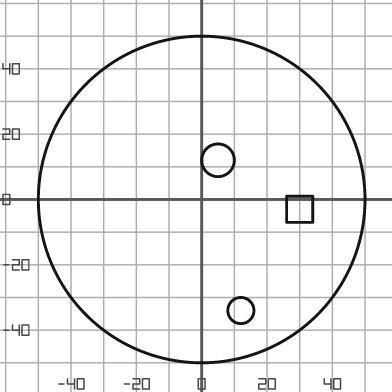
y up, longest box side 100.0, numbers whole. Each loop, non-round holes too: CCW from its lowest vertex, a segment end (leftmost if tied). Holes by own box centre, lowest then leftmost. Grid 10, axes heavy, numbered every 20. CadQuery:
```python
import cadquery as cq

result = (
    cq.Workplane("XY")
    .moveTo(0.0, 0.0)
    .circle(50.0)
    .moveTo(12.0, -34.0)
    .circle(4.0)
    .moveTo(26.0, -7.0)
    .lineTo(34.0, -7.0)
    .lineTo(34.0, 1.0)
    .lineTo(26.0, 1.0)
    .close()
    .moveTo(5.0, 12.0)
    .circle(5.0)
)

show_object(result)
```